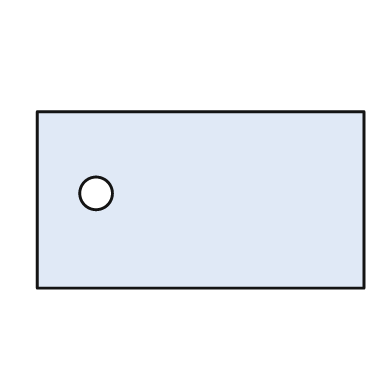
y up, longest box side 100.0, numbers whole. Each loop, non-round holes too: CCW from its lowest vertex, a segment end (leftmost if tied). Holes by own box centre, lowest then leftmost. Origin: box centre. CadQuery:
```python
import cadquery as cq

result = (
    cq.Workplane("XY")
    .moveTo(-50.0, -27.0)
    .lineTo(50.0, -27.0)
    .lineTo(50.0, 27.0)
    .lineTo(-50.0, 27.0)
    .close()
    .moveTo(-32.0, 2.0)
    .circle(5.0)
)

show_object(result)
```